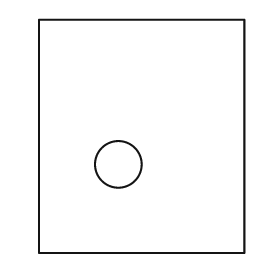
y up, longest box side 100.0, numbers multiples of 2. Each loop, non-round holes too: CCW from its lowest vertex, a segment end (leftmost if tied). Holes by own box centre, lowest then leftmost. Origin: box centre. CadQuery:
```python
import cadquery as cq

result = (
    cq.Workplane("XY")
    .moveTo(-44.0, -50.0)
    .lineTo(44.0, -50.0)
    .lineTo(44.0, 50.0)
    .lineTo(-44.0, 50.0)
    .close()
    .moveTo(-10.0, -12.0)
    .circle(10.0)
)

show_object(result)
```